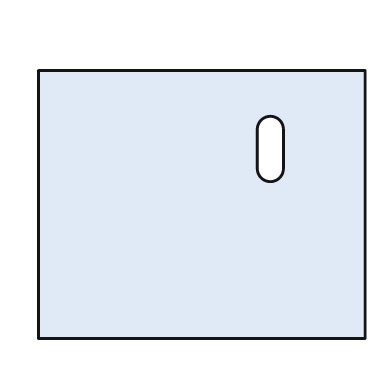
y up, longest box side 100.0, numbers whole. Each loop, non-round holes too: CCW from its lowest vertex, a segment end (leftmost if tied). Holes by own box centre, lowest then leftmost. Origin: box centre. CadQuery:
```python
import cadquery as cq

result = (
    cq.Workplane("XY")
    .moveTo(-50.0, -41.0)
    .lineTo(50.0, -41.0)
    .lineTo(50.0, 41.0)
    .lineTo(-50.0, 41.0)
    .close()
    .moveTo(17.0, 11.0)
    .threePointArc((21.0, 7.0), (25.0, 11.0))
    .lineTo(25.0, 23.0)
    .threePointArc((21.0, 27.0), (17.0, 23.0))
    .close()
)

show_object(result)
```